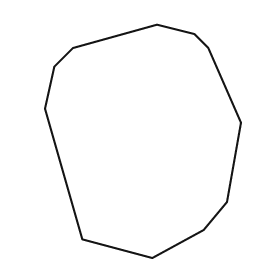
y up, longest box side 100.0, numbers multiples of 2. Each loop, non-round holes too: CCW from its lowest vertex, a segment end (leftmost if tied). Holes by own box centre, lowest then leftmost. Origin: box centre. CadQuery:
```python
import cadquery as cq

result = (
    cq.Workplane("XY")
    .moveTo(4.0, -50.0)
    .lineTo(26.0, -38.0)
    .lineTo(36.0, -26.0)
    .lineTo(42.0, 8.0)
    .lineTo(28.0, 40.0)
    .lineTo(22.0, 46.0)
    .lineTo(6.0, 50.0)
    .lineTo(-30.0, 40.0)
    .lineTo(-38.0, 32.0)
    .lineTo(-42.0, 14.0)
    .lineTo(-26.0, -42.0)
    .close()
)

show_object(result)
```